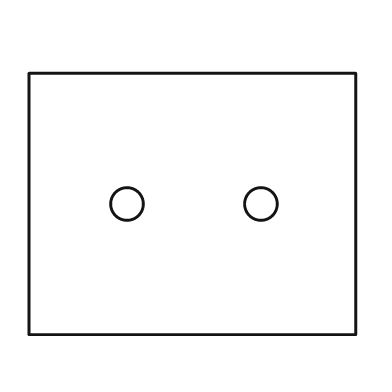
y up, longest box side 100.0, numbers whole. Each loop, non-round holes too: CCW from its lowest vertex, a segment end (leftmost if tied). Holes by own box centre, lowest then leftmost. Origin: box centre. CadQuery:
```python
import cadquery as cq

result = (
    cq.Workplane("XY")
    .moveTo(-50.0, -40.0)
    .lineTo(50.0, -40.0)
    .lineTo(50.0, 40.0)
    .lineTo(-50.0, 40.0)
    .close()
    .moveTo(-20.0, 0.0)
    .circle(5.0)
    .moveTo(21.0, 0.0)
    .circle(5.0)
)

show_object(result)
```